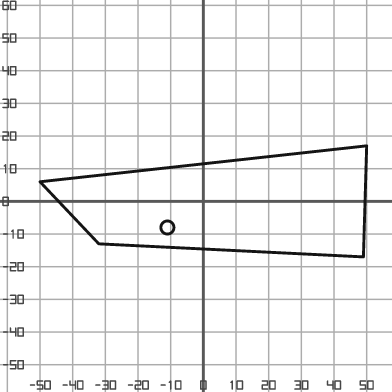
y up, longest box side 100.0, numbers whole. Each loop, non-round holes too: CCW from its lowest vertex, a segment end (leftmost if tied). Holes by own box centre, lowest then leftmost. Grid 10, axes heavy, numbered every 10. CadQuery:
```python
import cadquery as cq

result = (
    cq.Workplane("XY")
    .moveTo(49.0, -17.0)
    .lineTo(50.0, 17.0)
    .lineTo(-50.0, 6.0)
    .lineTo(-32.0, -13.0)
    .close()
    .moveTo(-11.0, -8.0)
    .circle(2.0)
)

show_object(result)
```